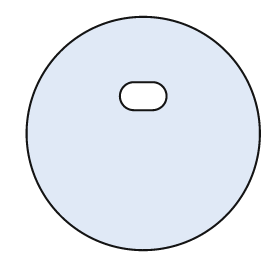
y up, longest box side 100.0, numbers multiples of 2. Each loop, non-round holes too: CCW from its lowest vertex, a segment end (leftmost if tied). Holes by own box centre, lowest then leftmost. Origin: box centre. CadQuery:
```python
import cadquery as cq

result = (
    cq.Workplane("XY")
    .moveTo(0.0, 0.0)
    .circle(50.0)
    .moveTo(-4.0, 10.0)
    .lineTo(4.0, 10.0)
    .threePointArc((10.0, 16.0), (4.0, 22.0))
    .lineTo(-4.0, 22.0)
    .threePointArc((-10.0, 16.0), (-4.0, 10.0))
    .close()
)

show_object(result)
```